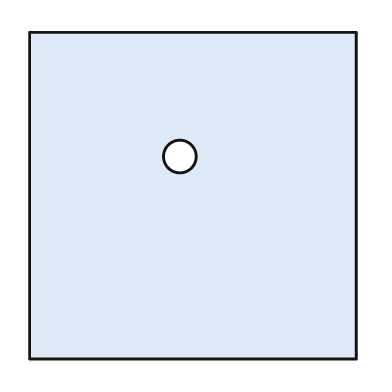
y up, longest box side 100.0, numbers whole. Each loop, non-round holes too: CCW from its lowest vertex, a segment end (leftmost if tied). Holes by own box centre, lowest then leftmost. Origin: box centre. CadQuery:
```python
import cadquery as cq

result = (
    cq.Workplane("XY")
    .moveTo(-50.0, -50.0)
    .lineTo(50.0, -50.0)
    .lineTo(50.0, 50.0)
    .lineTo(-50.0, 50.0)
    .close()
    .moveTo(-4.0, 12.0)
    .circle(5.0)
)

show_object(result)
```